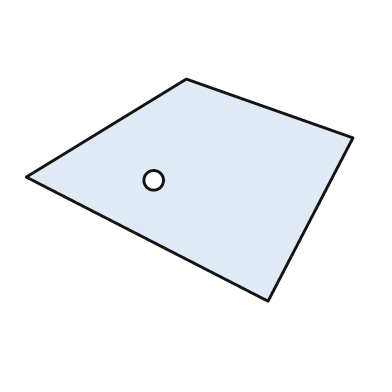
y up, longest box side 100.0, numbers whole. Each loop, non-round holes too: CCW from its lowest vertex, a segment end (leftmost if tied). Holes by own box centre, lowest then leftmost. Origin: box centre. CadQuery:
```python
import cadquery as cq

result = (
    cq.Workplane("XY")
    .moveTo(24.0, -34.0)
    .lineTo(50.0, 16.0)
    .lineTo(-1.0, 34.0)
    .lineTo(-50.0, 4.0)
    .close()
    .moveTo(-11.0, 3.0)
    .circle(3.0)
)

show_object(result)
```